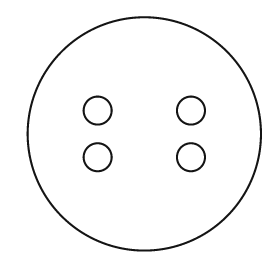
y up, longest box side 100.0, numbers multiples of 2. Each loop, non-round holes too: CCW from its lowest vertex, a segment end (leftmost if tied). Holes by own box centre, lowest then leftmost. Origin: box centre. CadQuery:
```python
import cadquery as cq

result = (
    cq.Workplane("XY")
    .moveTo(0.0, 0.0)
    .circle(50.0)
    .moveTo(-20.0, -10.0)
    .circle(6.0)
    .moveTo(20.0, -10.0)
    .circle(6.0)
    .moveTo(-20.0, 10.0)
    .circle(6.0)
    .moveTo(20.0, 10.0)
    .circle(6.0)
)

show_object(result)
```